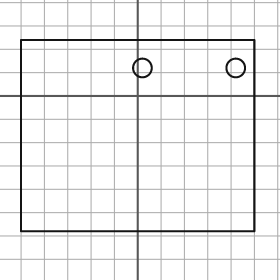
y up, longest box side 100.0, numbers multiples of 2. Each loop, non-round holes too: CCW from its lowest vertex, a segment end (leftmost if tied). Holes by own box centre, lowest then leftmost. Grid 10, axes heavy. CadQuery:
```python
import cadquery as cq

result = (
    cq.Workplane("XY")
    .moveTo(-50.0, -58.0)
    .lineTo(50.0, -58.0)
    .lineTo(50.0, 24.0)
    .lineTo(-50.0, 24.0)
    .close()
    .moveTo(2.0, 12.0)
    .circle(4.0)
    .moveTo(42.0, 12.0)
    .circle(4.0)
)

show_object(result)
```